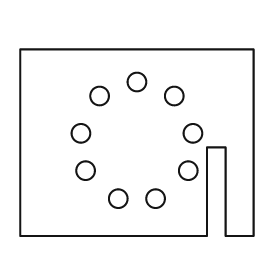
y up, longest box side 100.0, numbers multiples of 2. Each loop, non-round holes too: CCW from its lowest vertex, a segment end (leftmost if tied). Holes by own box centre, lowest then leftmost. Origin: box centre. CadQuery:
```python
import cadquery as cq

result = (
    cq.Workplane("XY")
    .moveTo(-50.0, -40.0)
    .lineTo(30.0, -40.0)
    .lineTo(30.0, -2.0)
    .lineTo(38.0, -2.0)
    .lineTo(38.0, -40.0)
    .lineTo(50.0, -40.0)
    .lineTo(50.0, 40.0)
    .lineTo(-50.0, 40.0)
    .close()
    .moveTo(-8.0, -24.0)
    .circle(4.0)
    .moveTo(8.0, -24.0)
    .circle(4.0)
    .moveTo(-22.0, -12.0)
    .circle(4.0)
    .moveTo(22.0, -12.0)
    .circle(4.0)
    .moveTo(-24.0, 4.0)
    .circle(4.0)
    .moveTo(24.0, 4.0)
    .circle(4.0)
    .moveTo(-16.0, 20.0)
    .circle(4.0)
    .moveTo(16.0, 20.0)
    .circle(4.0)
    .moveTo(0.0, 26.0)
    .circle(4.0)
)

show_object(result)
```